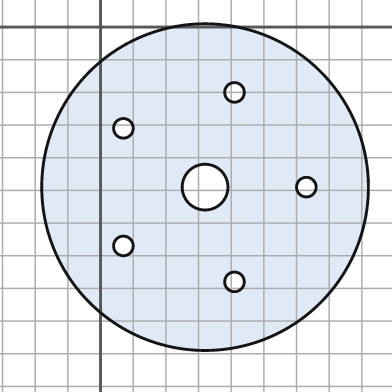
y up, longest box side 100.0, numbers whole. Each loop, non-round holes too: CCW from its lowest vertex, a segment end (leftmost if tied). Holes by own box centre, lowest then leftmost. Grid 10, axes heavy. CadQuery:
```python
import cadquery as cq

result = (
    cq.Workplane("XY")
    .moveTo(32.0, -49.0)
    .circle(50.0)
    .moveTo(41.0, -78.0)
    .circle(3.0)
    .moveTo(7.0, -67.0)
    .circle(3.0)
    .moveTo(32.0, -49.0)
    .circle(7.0)
    .moveTo(63.0, -49.0)
    .circle(3.0)
    .moveTo(7.0, -31.0)
    .circle(3.0)
    .moveTo(41.0, -20.0)
    .circle(3.0)
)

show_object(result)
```